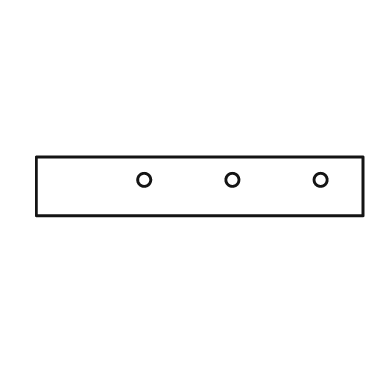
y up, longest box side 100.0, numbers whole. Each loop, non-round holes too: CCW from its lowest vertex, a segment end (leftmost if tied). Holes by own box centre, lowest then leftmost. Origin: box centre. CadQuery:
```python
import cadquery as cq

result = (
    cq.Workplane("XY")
    .moveTo(-50.0, -9.0)
    .lineTo(50.0, -9.0)
    .lineTo(50.0, 9.0)
    .lineTo(-50.0, 9.0)
    .close()
    .moveTo(-17.0, 2.0)
    .circle(2.0)
    .moveTo(10.0, 2.0)
    .circle(2.0)
    .moveTo(37.0, 2.0)
    .circle(2.0)
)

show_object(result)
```